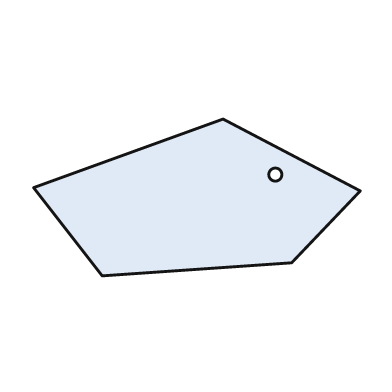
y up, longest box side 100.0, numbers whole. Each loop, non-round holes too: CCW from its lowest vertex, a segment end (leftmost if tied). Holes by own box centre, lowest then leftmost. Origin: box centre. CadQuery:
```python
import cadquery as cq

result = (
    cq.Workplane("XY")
    .moveTo(-29.0, -24.0)
    .lineTo(29.0, -20.0)
    .lineTo(50.0, 2.0)
    .lineTo(8.0, 24.0)
    .lineTo(-50.0, 3.0)
    .close()
    .moveTo(24.0, 7.0)
    .circle(2.0)
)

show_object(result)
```